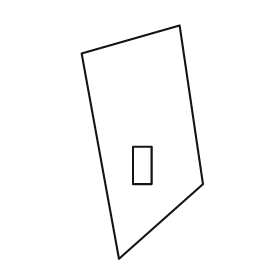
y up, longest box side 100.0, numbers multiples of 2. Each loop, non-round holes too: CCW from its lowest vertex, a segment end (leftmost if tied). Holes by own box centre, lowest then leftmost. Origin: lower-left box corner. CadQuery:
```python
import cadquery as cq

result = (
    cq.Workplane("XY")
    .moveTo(16.0, 0.0)
    .lineTo(52.0, 32.0)
    .lineTo(42.0, 100.0)
    .lineTo(0.0, 88.0)
    .close()
    .moveTo(22.0, 32.0)
    .lineTo(30.0, 32.0)
    .lineTo(30.0, 48.0)
    .lineTo(22.0, 48.0)
    .close()
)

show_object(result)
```